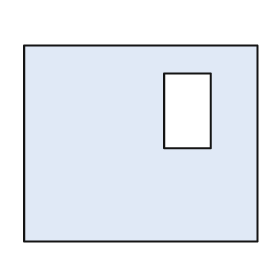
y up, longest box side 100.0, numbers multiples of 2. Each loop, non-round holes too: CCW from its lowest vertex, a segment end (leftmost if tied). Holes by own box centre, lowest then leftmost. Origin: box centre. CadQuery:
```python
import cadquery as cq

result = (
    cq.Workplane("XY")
    .moveTo(-50.0, -42.0)
    .lineTo(50.0, -42.0)
    .lineTo(50.0, 42.0)
    .lineTo(-50.0, 42.0)
    .close()
    .moveTo(10.0, -2.0)
    .lineTo(30.0, -2.0)
    .lineTo(30.0, 30.0)
    .lineTo(10.0, 30.0)
    .close()
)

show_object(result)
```